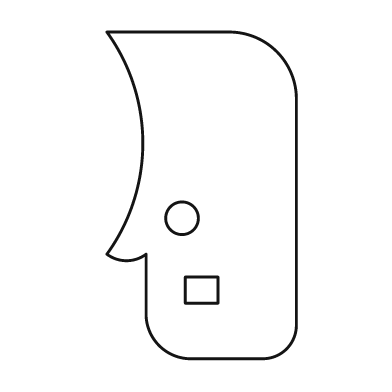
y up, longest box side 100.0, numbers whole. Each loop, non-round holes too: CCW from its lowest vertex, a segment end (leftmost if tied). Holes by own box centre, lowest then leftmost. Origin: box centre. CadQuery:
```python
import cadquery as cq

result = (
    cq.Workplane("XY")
    .moveTo(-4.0, -50.0)
    .lineTo(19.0, -50.0)
    .threePointArc((26.0, -47.0), (29.0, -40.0))
    .lineTo(29.0, 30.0)
    .threePointArc((23.0, 44.0), (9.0, 50.0))
    .lineTo(-29.0, 50.0)
    .threePointArc((-18.0, 16.0), (-29.0, -18.0))
    .threePointArc((-23.0, -20.0), (-17.0, -18.0))
    .lineTo(-17.0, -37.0)
    .threePointArc((-13.0, -46.0), (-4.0, -50.0))
    .close()
    .moveTo(-5.0, -33.0)
    .lineTo(5.0, -33.0)
    .lineTo(5.0, -25.0)
    .lineTo(-5.0, -25.0)
    .close()
    .moveTo(-6.0, -7.0)
    .circle(5.0)
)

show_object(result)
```